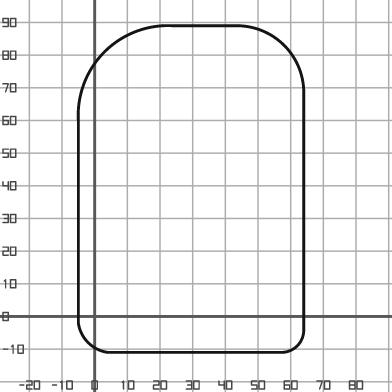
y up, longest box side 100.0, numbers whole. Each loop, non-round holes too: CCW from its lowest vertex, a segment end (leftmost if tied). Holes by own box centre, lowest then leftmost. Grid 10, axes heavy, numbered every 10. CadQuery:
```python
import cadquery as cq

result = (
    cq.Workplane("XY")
    .moveTo(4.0, -11.0)
    .lineTo(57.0, -11.0)
    .threePointArc((62.0, -9.0), (64.0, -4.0))
    .lineTo(64.0, 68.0)
    .threePointArc((58.0, 83.0), (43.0, 89.0))
    .lineTo(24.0, 89.0)
    .threePointArc((3.0, 81.0), (-5.0, 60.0))
    .lineTo(-5.0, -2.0)
    .threePointArc((-2.0, -8.0), (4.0, -11.0))
    .close()
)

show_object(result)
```